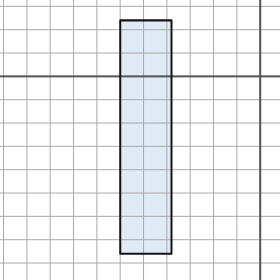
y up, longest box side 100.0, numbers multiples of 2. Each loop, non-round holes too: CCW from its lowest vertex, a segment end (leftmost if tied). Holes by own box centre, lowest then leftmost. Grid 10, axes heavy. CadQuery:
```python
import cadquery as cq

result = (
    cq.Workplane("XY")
    .moveTo(-60.0, -76.0)
    .lineTo(-38.0, -76.0)
    .lineTo(-38.0, 24.0)
    .lineTo(-60.0, 24.0)
    .close()
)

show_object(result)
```